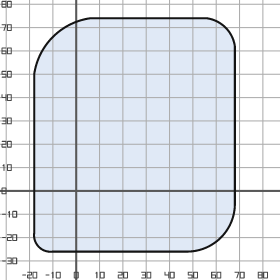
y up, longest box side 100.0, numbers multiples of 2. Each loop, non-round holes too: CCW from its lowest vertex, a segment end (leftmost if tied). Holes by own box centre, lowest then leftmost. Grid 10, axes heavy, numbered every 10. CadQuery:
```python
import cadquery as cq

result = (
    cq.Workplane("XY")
    .moveTo(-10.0, -26.0)
    .lineTo(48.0, -26.0)
    .threePointArc((62.0, -20.0), (68.0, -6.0))
    .lineTo(68.0, 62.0)
    .threePointArc((64.0, 70.0), (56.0, 74.0))
    .lineTo(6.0, 74.0)
    .threePointArc((-10.0, 66.0), (-18.0, 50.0))
    .lineTo(-18.0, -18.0)
    .threePointArc((-16.0, -24.0), (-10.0, -26.0))
    .close()
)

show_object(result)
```